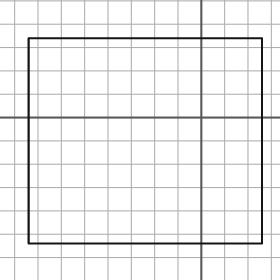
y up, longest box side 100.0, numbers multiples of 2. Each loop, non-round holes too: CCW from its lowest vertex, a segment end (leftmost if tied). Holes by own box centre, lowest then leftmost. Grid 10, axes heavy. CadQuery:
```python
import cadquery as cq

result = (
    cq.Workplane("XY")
    .moveTo(-74.0, -54.0)
    .lineTo(26.0, -54.0)
    .lineTo(26.0, 34.0)
    .lineTo(-74.0, 34.0)
    .close()
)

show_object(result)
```